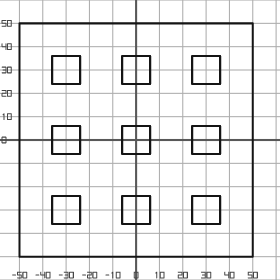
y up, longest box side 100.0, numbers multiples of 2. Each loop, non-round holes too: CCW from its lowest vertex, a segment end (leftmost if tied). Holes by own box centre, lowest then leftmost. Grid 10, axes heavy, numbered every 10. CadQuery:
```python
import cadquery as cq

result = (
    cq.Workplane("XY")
    .moveTo(-50.0, -50.0)
    .lineTo(50.0, -50.0)
    .lineTo(50.0, 50.0)
    .lineTo(-50.0, 50.0)
    .close()
    .moveTo(-36.0, -36.0)
    .lineTo(-24.0, -36.0)
    .lineTo(-24.0, -24.0)
    .lineTo(-36.0, -24.0)
    .close()
    .moveTo(-6.0, -36.0)
    .lineTo(6.0, -36.0)
    .lineTo(6.0, -24.0)
    .lineTo(-6.0, -24.0)
    .close()
    .moveTo(24.0, -36.0)
    .lineTo(36.0, -36.0)
    .lineTo(36.0, -24.0)
    .lineTo(24.0, -24.0)
    .close()
    .moveTo(-36.0, -6.0)
    .lineTo(-24.0, -6.0)
    .lineTo(-24.0, 6.0)
    .lineTo(-36.0, 6.0)
    .close()
    .moveTo(-6.0, -6.0)
    .lineTo(6.0, -6.0)
    .lineTo(6.0, 6.0)
    .lineTo(-6.0, 6.0)
    .close()
    .moveTo(24.0, -6.0)
    .lineTo(36.0, -6.0)
    .lineTo(36.0, 6.0)
    .lineTo(24.0, 6.0)
    .close()
    .moveTo(-36.0, 24.0)
    .lineTo(-24.0, 24.0)
    .lineTo(-24.0, 36.0)
    .lineTo(-36.0, 36.0)
    .close()
    .moveTo(-6.0, 24.0)
    .lineTo(6.0, 24.0)
    .lineTo(6.0, 36.0)
    .lineTo(-6.0, 36.0)
    .close()
    .moveTo(24.0, 24.0)
    .lineTo(36.0, 24.0)
    .lineTo(36.0, 36.0)
    .lineTo(24.0, 36.0)
    .close()
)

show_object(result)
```